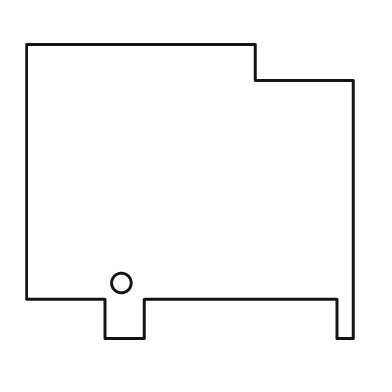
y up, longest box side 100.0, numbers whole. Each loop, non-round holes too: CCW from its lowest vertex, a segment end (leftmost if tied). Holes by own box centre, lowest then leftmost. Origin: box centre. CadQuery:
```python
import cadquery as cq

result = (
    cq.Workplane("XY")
    .moveTo(-26.0, -45.0)
    .lineTo(-14.0, -45.0)
    .lineTo(-14.0, -33.0)
    .lineTo(45.0, -33.0)
    .lineTo(45.0, -45.0)
    .lineTo(50.0, -45.0)
    .lineTo(50.0, 34.0)
    .lineTo(20.0, 34.0)
    .lineTo(20.0, 45.0)
    .lineTo(-50.0, 45.0)
    .lineTo(-50.0, -33.0)
    .lineTo(-26.0, -33.0)
    .close()
    .moveTo(-21.0, -28.0)
    .circle(3.0)
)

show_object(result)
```